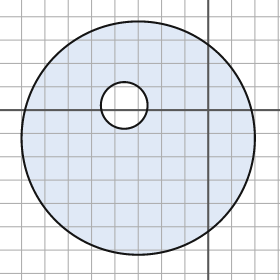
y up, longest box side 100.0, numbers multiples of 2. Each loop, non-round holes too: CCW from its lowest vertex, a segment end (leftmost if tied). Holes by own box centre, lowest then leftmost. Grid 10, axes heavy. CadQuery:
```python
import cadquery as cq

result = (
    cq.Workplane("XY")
    .moveTo(-30.0, -12.0)
    .circle(50.0)
    .moveTo(-36.0, 2.0)
    .circle(10.0)
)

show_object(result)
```